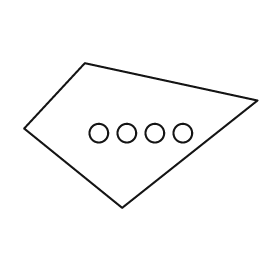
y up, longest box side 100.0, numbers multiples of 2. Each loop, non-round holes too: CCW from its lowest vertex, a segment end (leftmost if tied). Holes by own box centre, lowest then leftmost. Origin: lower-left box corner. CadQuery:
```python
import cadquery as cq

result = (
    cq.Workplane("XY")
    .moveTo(42.0, 0.0)
    .lineTo(100.0, 46.0)
    .lineTo(26.0, 62.0)
    .lineTo(0.0, 34.0)
    .close()
    .moveTo(32.0, 32.0)
    .circle(4.0)
    .moveTo(44.0, 32.0)
    .circle(4.0)
    .moveTo(56.0, 32.0)
    .circle(4.0)
    .moveTo(68.0, 32.0)
    .circle(4.0)
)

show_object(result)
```